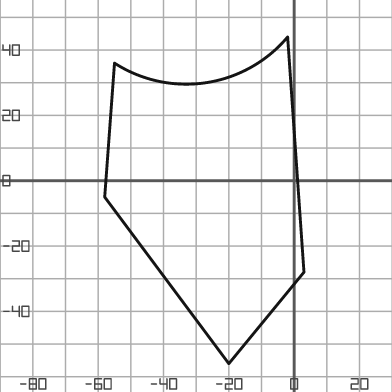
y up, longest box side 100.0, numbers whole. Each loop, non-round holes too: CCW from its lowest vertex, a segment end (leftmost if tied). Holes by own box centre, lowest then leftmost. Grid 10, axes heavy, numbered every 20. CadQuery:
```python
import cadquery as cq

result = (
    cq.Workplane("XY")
    .moveTo(-20.0, -56.0)
    .lineTo(3.0, -28.0)
    .lineTo(-2.0, 44.0)
    .threePointArc((-27.0, 30.0), (-55.0, 36.0))
    .lineTo(-58.0, -5.0)
    .close()
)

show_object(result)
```